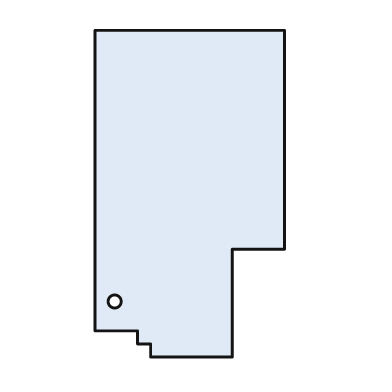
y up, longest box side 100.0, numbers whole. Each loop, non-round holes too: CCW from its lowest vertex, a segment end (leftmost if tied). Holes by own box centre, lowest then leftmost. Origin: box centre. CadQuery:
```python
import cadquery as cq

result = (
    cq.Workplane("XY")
    .moveTo(-12.0, -50.0)
    .lineTo(13.0, -50.0)
    .lineTo(13.0, -17.0)
    .lineTo(29.0, -17.0)
    .lineTo(29.0, 50.0)
    .lineTo(-29.0, 50.0)
    .lineTo(-29.0, -42.0)
    .lineTo(-16.0, -42.0)
    .lineTo(-16.0, -46.0)
    .lineTo(-12.0, -46.0)
    .close()
    .moveTo(-23.0, -33.0)
    .circle(2.0)
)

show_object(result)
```